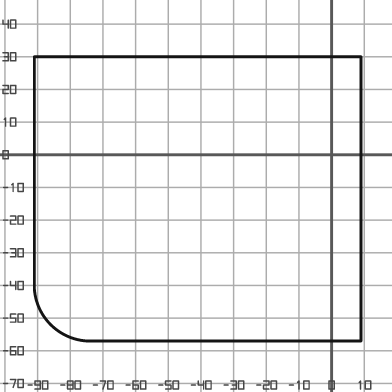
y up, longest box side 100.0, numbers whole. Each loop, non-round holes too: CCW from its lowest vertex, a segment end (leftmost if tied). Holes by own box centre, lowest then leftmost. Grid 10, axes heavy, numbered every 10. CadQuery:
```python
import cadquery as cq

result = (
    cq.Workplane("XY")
    .moveTo(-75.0, -57.0)
    .lineTo(9.0, -57.0)
    .lineTo(9.0, 30.0)
    .lineTo(-91.0, 30.0)
    .lineTo(-91.0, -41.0)
    .threePointArc((-86.0, -52.0), (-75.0, -57.0))
    .close()
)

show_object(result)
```